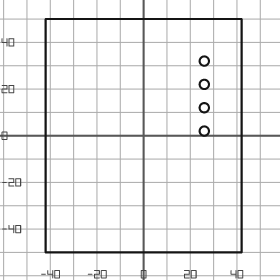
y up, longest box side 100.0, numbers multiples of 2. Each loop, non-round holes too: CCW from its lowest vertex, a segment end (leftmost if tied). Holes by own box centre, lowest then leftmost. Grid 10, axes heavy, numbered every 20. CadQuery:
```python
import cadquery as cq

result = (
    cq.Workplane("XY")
    .moveTo(-42.0, -50.0)
    .lineTo(42.0, -50.0)
    .lineTo(42.0, 50.0)
    .lineTo(-42.0, 50.0)
    .close()
    .moveTo(26.0, 2.0)
    .circle(2.0)
    .moveTo(26.0, 12.0)
    .circle(2.0)
    .moveTo(26.0, 22.0)
    .circle(2.0)
    .moveTo(26.0, 32.0)
    .circle(2.0)
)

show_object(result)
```